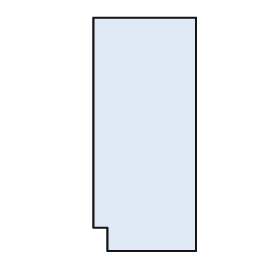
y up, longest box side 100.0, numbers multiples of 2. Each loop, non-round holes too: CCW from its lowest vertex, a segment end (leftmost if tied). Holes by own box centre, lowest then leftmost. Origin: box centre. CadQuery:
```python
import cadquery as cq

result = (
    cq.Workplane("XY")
    .moveTo(-16.0, -50.0)
    .lineTo(22.0, -50.0)
    .lineTo(22.0, 50.0)
    .lineTo(-22.0, 50.0)
    .lineTo(-22.0, -40.0)
    .lineTo(-16.0, -40.0)
    .close()
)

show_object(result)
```